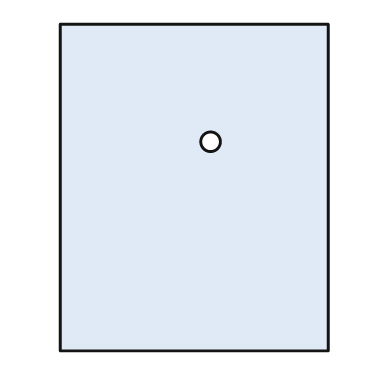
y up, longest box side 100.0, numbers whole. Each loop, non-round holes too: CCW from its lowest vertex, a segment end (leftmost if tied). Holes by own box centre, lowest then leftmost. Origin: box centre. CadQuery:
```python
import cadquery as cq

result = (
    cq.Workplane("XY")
    .moveTo(-41.0, -50.0)
    .lineTo(41.0, -50.0)
    .lineTo(41.0, 50.0)
    .lineTo(-41.0, 50.0)
    .close()
    .moveTo(5.0, 14.0)
    .circle(3.0)
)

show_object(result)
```